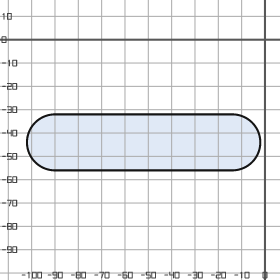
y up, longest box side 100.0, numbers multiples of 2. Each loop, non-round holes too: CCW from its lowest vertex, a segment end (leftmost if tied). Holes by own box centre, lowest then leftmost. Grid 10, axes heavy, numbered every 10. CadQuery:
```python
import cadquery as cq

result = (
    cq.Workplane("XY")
    .moveTo(-90.0, -56.0)
    .lineTo(-14.0, -56.0)
    .threePointArc((-2.0, -44.0), (-14.0, -32.0))
    .lineTo(-90.0, -32.0)
    .threePointArc((-102.0, -44.0), (-90.0, -56.0))
    .close()
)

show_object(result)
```